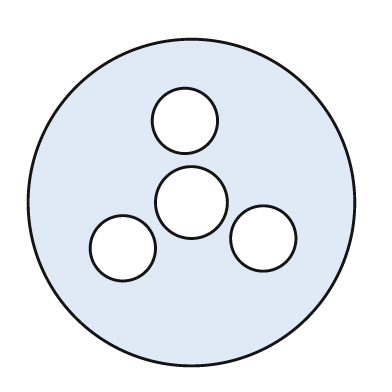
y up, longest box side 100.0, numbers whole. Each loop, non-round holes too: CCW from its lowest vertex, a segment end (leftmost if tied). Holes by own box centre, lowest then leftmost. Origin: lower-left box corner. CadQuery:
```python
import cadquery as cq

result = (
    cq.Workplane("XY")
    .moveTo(50.0, 50.0)
    .circle(50.0)
    .moveTo(29.0, 36.0)
    .circle(10.0)
    .moveTo(72.0, 39.0)
    .circle(10.0)
    .moveTo(50.0, 50.0)
    .circle(11.0)
    .moveTo(48.0, 75.0)
    .circle(10.0)
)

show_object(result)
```